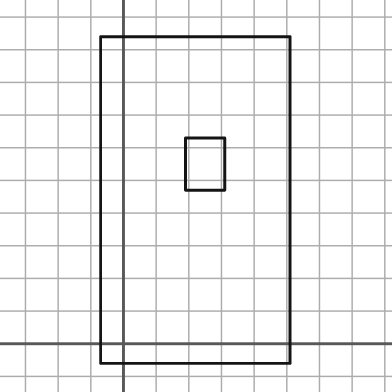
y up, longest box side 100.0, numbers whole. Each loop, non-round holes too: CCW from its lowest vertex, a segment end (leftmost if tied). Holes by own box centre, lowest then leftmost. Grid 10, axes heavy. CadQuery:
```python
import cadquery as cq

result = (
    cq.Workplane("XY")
    .moveTo(-7.0, -6.0)
    .lineTo(51.0, -6.0)
    .lineTo(51.0, 94.0)
    .lineTo(-7.0, 94.0)
    .close()
    .moveTo(19.0, 47.0)
    .lineTo(31.0, 47.0)
    .lineTo(31.0, 63.0)
    .lineTo(19.0, 63.0)
    .close()
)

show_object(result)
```